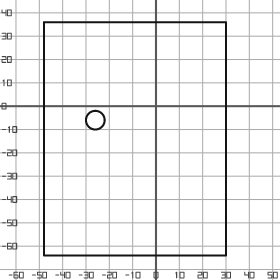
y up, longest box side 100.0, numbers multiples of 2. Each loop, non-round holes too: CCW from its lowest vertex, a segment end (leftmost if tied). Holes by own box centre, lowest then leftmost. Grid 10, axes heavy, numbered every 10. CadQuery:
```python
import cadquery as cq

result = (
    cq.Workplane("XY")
    .moveTo(-48.0, -64.0)
    .lineTo(30.0, -64.0)
    .lineTo(30.0, 36.0)
    .lineTo(-48.0, 36.0)
    .close()
    .moveTo(-26.0, -6.0)
    .circle(4.0)
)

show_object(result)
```